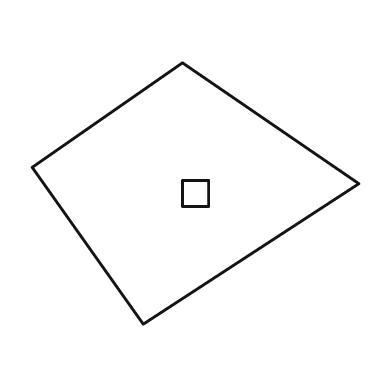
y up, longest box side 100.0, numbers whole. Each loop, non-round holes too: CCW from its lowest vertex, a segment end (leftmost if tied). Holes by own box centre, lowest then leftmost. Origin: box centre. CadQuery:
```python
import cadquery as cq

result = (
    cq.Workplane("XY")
    .moveTo(-16.0, -40.0)
    .lineTo(50.0, 3.0)
    .lineTo(-4.0, 40.0)
    .lineTo(-50.0, 8.0)
    .close()
    .moveTo(-4.0, -4.0)
    .lineTo(4.0, -4.0)
    .lineTo(4.0, 4.0)
    .lineTo(-4.0, 4.0)
    .close()
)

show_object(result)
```